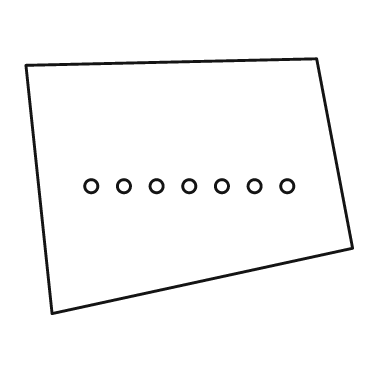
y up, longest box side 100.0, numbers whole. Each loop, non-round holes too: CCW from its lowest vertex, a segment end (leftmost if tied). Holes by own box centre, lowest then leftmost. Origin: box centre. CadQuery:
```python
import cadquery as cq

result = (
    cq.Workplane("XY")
    .moveTo(-42.0, -39.0)
    .lineTo(50.0, -19.0)
    .lineTo(39.0, 39.0)
    .lineTo(-50.0, 37.0)
    .close()
    .moveTo(-30.0, 0.0)
    .circle(2.0)
    .moveTo(-20.0, 0.0)
    .circle(2.0)
    .moveTo(-10.0, 0.0)
    .circle(2.0)
    .moveTo(0.0, 0.0)
    .circle(2.0)
    .moveTo(10.0, 0.0)
    .circle(2.0)
    .moveTo(20.0, 0.0)
    .circle(2.0)
    .moveTo(30.0, 0.0)
    .circle(2.0)
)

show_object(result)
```